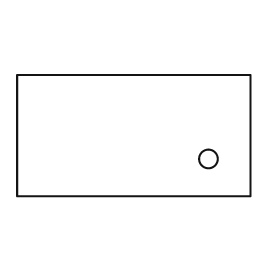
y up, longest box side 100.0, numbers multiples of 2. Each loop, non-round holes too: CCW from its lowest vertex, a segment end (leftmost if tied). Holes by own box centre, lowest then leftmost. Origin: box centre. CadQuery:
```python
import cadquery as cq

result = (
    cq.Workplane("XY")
    .moveTo(-50.0, -26.0)
    .lineTo(50.0, -26.0)
    .lineTo(50.0, 26.0)
    .lineTo(-50.0, 26.0)
    .close()
    .moveTo(32.0, -10.0)
    .circle(4.0)
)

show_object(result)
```